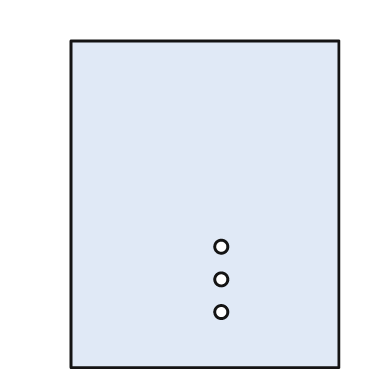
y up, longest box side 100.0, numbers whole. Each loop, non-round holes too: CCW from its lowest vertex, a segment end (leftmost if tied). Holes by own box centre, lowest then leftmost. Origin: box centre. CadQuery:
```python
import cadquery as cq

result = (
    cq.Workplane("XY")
    .moveTo(-41.0, -50.0)
    .lineTo(41.0, -50.0)
    .lineTo(41.0, 50.0)
    .lineTo(-41.0, 50.0)
    .close()
    .moveTo(5.0, -33.0)
    .circle(2.0)
    .moveTo(5.0, -23.0)
    .circle(2.0)
    .moveTo(5.0, -13.0)
    .circle(2.0)
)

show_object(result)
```